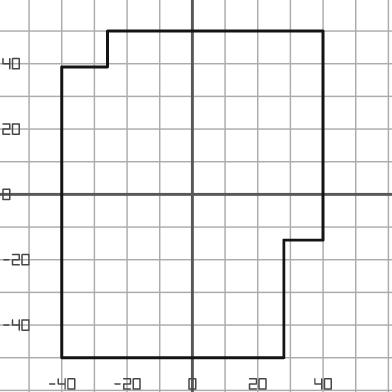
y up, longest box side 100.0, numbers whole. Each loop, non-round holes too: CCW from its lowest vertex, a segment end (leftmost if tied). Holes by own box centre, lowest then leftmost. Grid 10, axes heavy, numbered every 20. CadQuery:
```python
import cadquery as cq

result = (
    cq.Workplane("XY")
    .moveTo(-40.0, -50.0)
    .lineTo(28.0, -50.0)
    .lineTo(28.0, -14.0)
    .lineTo(40.0, -14.0)
    .lineTo(40.0, 50.0)
    .lineTo(-26.0, 50.0)
    .lineTo(-26.0, 39.0)
    .lineTo(-40.0, 39.0)
    .close()
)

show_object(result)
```